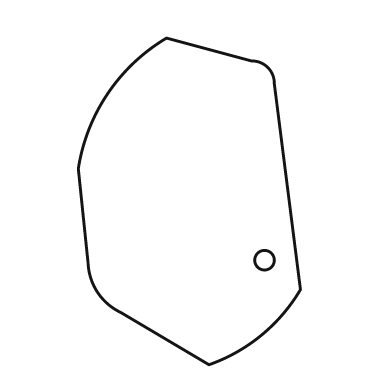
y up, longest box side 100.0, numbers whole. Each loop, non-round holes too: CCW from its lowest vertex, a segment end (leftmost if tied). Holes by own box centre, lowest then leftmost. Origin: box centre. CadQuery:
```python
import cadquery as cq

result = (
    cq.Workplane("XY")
    .moveTo(6.0, -50.0)
    .threePointArc((22.0, -41.0), (34.0, -27.0))
    .lineTo(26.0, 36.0)
    .threePointArc((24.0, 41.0), (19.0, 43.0))
    .lineTo(-7.0, 50.0)
    .threePointArc((-25.0, 33.0), (-34.0, 10.0))
    .lineTo(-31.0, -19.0)
    .threePointArc((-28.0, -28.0), (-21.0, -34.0))
    .close()
    .moveTo(23.0, -18.0)
    .circle(3.0)
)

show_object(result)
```